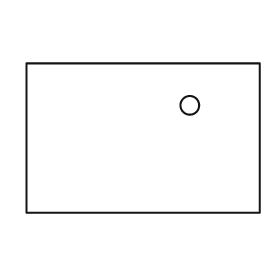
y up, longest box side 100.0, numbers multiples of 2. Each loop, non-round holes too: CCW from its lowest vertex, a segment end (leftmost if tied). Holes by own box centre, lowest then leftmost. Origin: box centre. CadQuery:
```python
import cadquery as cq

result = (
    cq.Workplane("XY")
    .moveTo(-50.0, -32.0)
    .lineTo(50.0, -32.0)
    .lineTo(50.0, 32.0)
    .lineTo(-50.0, 32.0)
    .close()
    .moveTo(20.0, 14.0)
    .circle(4.0)
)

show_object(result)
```